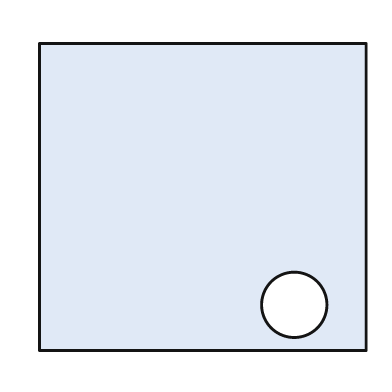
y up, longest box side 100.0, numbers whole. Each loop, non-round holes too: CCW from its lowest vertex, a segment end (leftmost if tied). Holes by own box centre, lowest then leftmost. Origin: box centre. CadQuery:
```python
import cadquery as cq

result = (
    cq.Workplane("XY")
    .moveTo(-50.0, -47.0)
    .lineTo(50.0, -47.0)
    .lineTo(50.0, 47.0)
    .lineTo(-50.0, 47.0)
    .close()
    .moveTo(28.0, -33.0)
    .circle(10.0)
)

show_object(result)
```